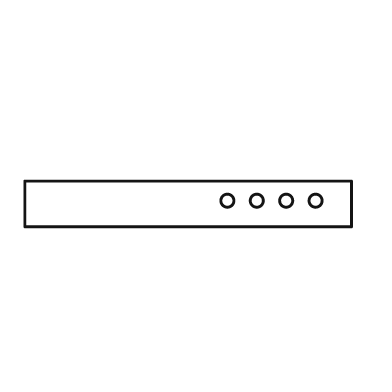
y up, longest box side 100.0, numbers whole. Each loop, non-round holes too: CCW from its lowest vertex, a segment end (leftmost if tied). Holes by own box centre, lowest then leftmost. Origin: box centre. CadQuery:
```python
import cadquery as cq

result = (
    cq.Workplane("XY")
    .moveTo(-50.0, -7.0)
    .lineTo(50.0, -7.0)
    .lineTo(50.0, 7.0)
    .lineTo(-50.0, 7.0)
    .close()
    .moveTo(12.0, 1.0)
    .circle(2.0)
    .moveTo(21.0, 1.0)
    .circle(2.0)
    .moveTo(30.0, 1.0)
    .circle(2.0)
    .moveTo(39.0, 1.0)
    .circle(2.0)
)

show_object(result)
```